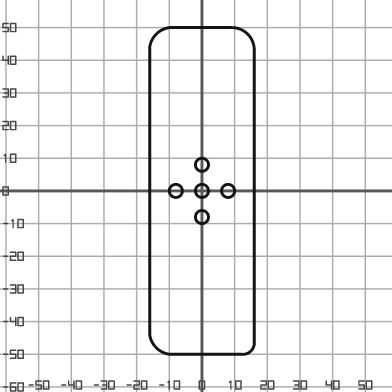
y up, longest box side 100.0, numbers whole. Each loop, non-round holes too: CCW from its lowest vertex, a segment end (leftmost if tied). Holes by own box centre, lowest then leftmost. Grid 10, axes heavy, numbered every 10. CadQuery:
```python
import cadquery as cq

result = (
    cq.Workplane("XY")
    .moveTo(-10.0, -50.0)
    .lineTo(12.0, -50.0)
    .threePointArc((15.0, -49.0), (16.0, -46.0))
    .lineTo(16.0, 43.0)
    .threePointArc((14.0, 48.0), (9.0, 50.0))
    .lineTo(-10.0, 50.0)
    .threePointArc((-14.0, 48.0), (-16.0, 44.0))
    .lineTo(-16.0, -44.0)
    .threePointArc((-14.0, -48.0), (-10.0, -50.0))
    .close()
    .moveTo(0.0, -8.0)
    .circle(2.0)
    .moveTo(-8.0, 0.0)
    .circle(2.0)
    .moveTo(0.0, 0.0)
    .circle(2.0)
    .moveTo(8.0, 0.0)
    .circle(2.0)
    .moveTo(0.0, 8.0)
    .circle(2.0)
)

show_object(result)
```